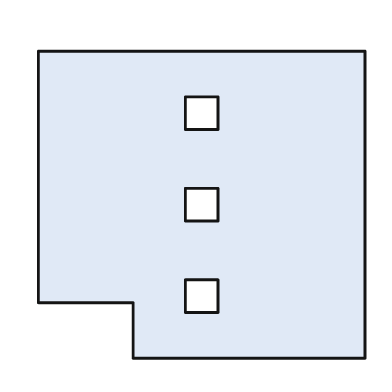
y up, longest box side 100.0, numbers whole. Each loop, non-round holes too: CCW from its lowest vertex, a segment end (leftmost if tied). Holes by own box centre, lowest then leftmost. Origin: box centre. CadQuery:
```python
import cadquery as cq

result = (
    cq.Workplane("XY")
    .moveTo(-21.0, -47.0)
    .lineTo(50.0, -47.0)
    .lineTo(50.0, 47.0)
    .lineTo(-50.0, 47.0)
    .lineTo(-50.0, -30.0)
    .lineTo(-21.0, -30.0)
    .close()
    .moveTo(-5.0, -33.0)
    .lineTo(5.0, -33.0)
    .lineTo(5.0, -23.0)
    .lineTo(-5.0, -23.0)
    .close()
    .moveTo(-5.0, -5.0)
    .lineTo(5.0, -5.0)
    .lineTo(5.0, 5.0)
    .lineTo(-5.0, 5.0)
    .close()
    .moveTo(-5.0, 23.0)
    .lineTo(5.0, 23.0)
    .lineTo(5.0, 33.0)
    .lineTo(-5.0, 33.0)
    .close()
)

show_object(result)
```